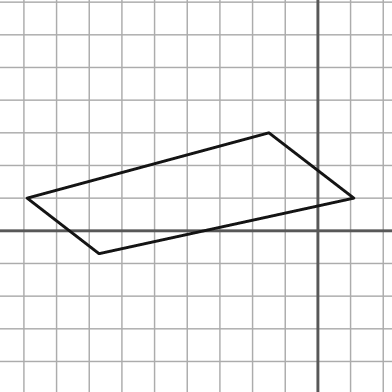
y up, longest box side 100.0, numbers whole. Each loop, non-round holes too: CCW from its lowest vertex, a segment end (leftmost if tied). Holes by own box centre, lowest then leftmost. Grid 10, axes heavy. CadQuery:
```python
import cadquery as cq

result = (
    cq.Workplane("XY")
    .moveTo(-67.0, -7.0)
    .lineTo(11.0, 10.0)
    .lineTo(-15.0, 30.0)
    .lineTo(-89.0, 10.0)
    .close()
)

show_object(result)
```